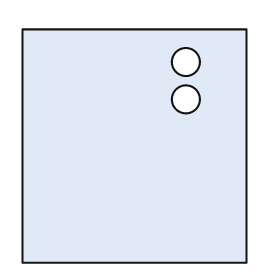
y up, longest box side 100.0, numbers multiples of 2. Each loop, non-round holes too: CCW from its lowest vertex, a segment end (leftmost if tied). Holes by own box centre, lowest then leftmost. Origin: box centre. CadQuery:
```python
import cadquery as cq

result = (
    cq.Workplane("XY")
    .moveTo(-48.0, -50.0)
    .lineTo(48.0, -50.0)
    .lineTo(48.0, 50.0)
    .lineTo(-48.0, 50.0)
    .close()
    .moveTo(22.0, 20.0)
    .circle(6.0)
    .moveTo(22.0, 36.0)
    .circle(6.0)
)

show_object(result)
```